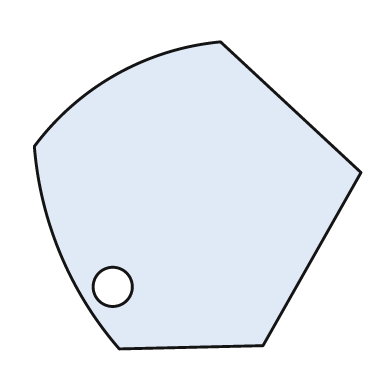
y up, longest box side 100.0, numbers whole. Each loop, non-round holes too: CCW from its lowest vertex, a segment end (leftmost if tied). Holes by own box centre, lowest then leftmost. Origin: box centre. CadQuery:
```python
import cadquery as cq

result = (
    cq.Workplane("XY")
    .moveTo(-24.0, -47.0)
    .lineTo(20.0, -46.0)
    .lineTo(50.0, 7.0)
    .lineTo(7.0, 47.0)
    .threePointArc((-25.0, 37.0), (-50.0, 15.0))
    .threePointArc((-42.0, -18.0), (-24.0, -47.0))
    .close()
    .moveTo(-26.0, -28.0)
    .circle(6.0)
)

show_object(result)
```